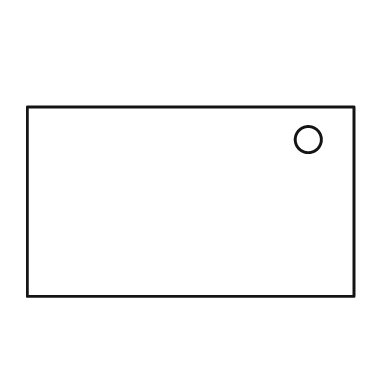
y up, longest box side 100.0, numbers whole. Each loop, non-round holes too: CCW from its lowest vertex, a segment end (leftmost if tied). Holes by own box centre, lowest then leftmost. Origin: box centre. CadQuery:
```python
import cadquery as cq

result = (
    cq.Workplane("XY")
    .moveTo(-50.0, -29.0)
    .lineTo(50.0, -29.0)
    .lineTo(50.0, 29.0)
    .lineTo(-50.0, 29.0)
    .close()
    .moveTo(36.0, 19.0)
    .circle(4.0)
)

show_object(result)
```